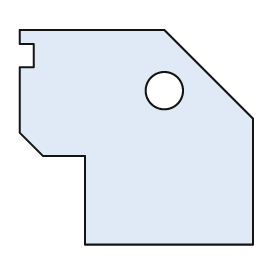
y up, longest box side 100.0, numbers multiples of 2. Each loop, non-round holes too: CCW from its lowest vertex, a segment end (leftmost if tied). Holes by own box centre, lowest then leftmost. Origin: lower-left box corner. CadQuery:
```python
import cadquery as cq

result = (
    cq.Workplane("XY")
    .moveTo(28.0, 0.0)
    .lineTo(100.0, 0.0)
    .lineTo(100.0, 54.0)
    .lineTo(62.0, 92.0)
    .lineTo(0.0, 92.0)
    .lineTo(0.0, 86.0)
    .lineTo(6.0, 86.0)
    .lineTo(6.0, 76.0)
    .lineTo(0.0, 76.0)
    .lineTo(0.0, 48.0)
    .lineTo(10.0, 38.0)
    .lineTo(28.0, 38.0)
    .close()
    .moveTo(62.0, 66.0)
    .circle(8.0)
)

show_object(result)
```